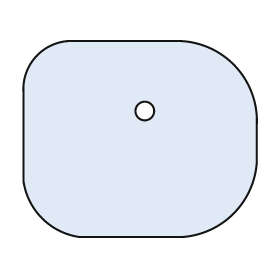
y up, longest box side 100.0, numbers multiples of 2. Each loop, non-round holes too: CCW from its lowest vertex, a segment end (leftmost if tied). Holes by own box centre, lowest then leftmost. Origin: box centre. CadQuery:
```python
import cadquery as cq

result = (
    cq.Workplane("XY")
    .moveTo(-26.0, -42.0)
    .lineTo(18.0, -42.0)
    .threePointArc((40.0, -32.0), (50.0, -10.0))
    .lineTo(50.0, 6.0)
    .threePointArc((40.0, 32.0), (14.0, 42.0))
    .lineTo(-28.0, 42.0)
    .threePointArc((-44.0, 36.0), (-50.0, 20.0))
    .lineTo(-50.0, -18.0)
    .threePointArc((-42.0, -34.0), (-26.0, -42.0))
    .close()
    .moveTo(2.0, 12.0)
    .circle(4.0)
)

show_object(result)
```